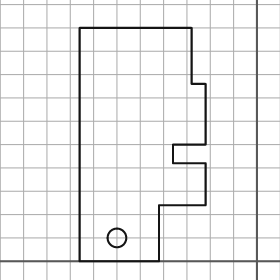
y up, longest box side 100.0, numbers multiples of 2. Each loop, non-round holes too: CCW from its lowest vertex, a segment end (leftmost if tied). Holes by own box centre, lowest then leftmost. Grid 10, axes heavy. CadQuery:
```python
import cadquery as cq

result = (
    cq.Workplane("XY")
    .moveTo(-76.0, 0.0)
    .lineTo(-42.0, 0.0)
    .lineTo(-42.0, 24.0)
    .lineTo(-22.0, 24.0)
    .lineTo(-22.0, 42.0)
    .lineTo(-36.0, 42.0)
    .lineTo(-36.0, 50.0)
    .lineTo(-22.0, 50.0)
    .lineTo(-22.0, 76.0)
    .lineTo(-28.0, 76.0)
    .lineTo(-28.0, 100.0)
    .lineTo(-76.0, 100.0)
    .close()
    .moveTo(-60.0, 10.0)
    .circle(4.0)
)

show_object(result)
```